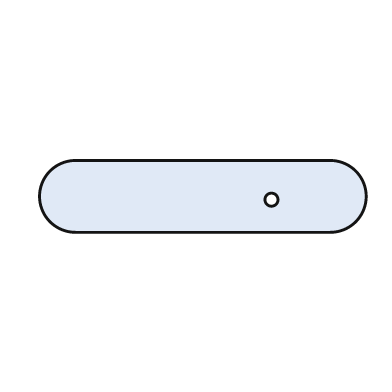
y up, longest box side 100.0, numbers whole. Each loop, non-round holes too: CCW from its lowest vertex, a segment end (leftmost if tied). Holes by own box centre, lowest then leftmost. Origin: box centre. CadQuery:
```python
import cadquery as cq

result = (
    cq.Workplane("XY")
    .moveTo(-39.0, -11.0)
    .lineTo(39.0, -11.0)
    .threePointArc((50.0, 0.0), (39.0, 11.0))
    .lineTo(-39.0, 11.0)
    .threePointArc((-50.0, 0.0), (-39.0, -11.0))
    .close()
    .moveTo(21.0, -1.0)
    .circle(2.0)
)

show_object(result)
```